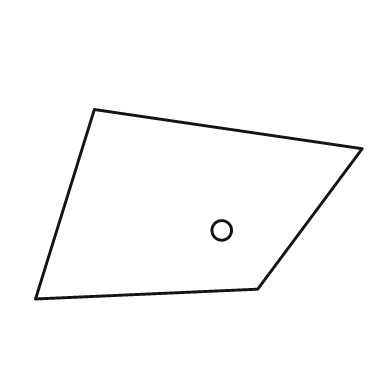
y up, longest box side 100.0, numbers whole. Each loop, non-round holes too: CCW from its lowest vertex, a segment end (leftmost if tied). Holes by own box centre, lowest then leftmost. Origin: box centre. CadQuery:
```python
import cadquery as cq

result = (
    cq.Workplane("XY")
    .moveTo(-50.0, -29.0)
    .lineTo(18.0, -26.0)
    .lineTo(50.0, 17.0)
    .lineTo(-32.0, 29.0)
    .close()
    .moveTo(7.0, -8.0)
    .circle(3.0)
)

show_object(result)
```